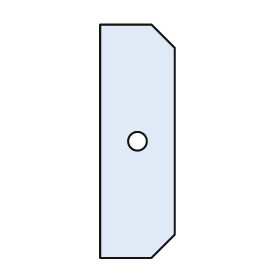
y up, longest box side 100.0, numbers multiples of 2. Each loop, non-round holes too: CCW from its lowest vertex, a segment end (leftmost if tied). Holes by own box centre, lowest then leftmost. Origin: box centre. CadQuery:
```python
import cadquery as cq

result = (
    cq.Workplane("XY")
    .moveTo(-16.0, -50.0)
    .lineTo(6.0, -50.0)
    .lineTo(16.0, -40.0)
    .lineTo(16.0, 40.0)
    .lineTo(6.0, 50.0)
    .lineTo(-16.0, 50.0)
    .close()
    .moveTo(0.0, 0.0)
    .circle(4.0)
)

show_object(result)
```